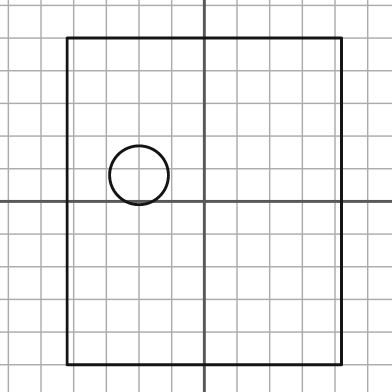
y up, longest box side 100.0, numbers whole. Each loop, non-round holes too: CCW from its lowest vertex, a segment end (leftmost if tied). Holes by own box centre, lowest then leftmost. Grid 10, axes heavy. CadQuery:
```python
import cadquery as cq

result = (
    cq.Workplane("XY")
    .moveTo(-42.0, -50.0)
    .lineTo(42.0, -50.0)
    .lineTo(42.0, 50.0)
    .lineTo(-42.0, 50.0)
    .close()
    .moveTo(-20.0, 8.0)
    .circle(9.0)
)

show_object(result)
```